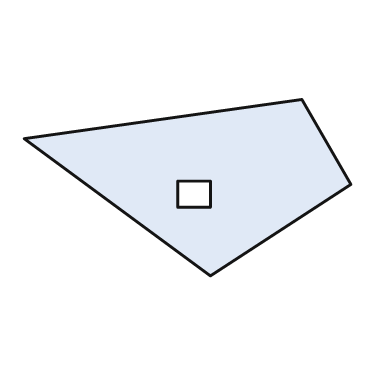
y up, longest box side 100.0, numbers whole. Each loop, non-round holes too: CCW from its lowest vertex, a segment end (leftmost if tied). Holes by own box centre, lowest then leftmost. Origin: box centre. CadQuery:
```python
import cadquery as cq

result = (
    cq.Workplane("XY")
    .moveTo(7.0, -27.0)
    .lineTo(50.0, 1.0)
    .lineTo(35.0, 27.0)
    .lineTo(-50.0, 15.0)
    .close()
    .moveTo(-3.0, -6.0)
    .lineTo(7.0, -6.0)
    .lineTo(7.0, 2.0)
    .lineTo(-3.0, 2.0)
    .close()
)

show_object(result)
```